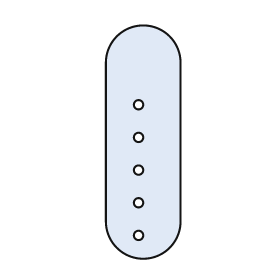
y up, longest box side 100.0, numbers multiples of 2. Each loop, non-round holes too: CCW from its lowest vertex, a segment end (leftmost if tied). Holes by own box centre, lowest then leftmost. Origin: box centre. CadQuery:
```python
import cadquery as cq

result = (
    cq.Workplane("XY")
    .moveTo(-16.0, -34.0)
    .threePointArc((0.0, -50.0), (16.0, -34.0))
    .lineTo(16.0, 34.0)
    .threePointArc((0.0, 50.0), (-16.0, 34.0))
    .close()
    .moveTo(-2.0, -40.0)
    .circle(2.0)
    .moveTo(-2.0, -26.0)
    .circle(2.0)
    .moveTo(-2.0, -12.0)
    .circle(2.0)
    .moveTo(-2.0, 2.0)
    .circle(2.0)
    .moveTo(-2.0, 16.0)
    .circle(2.0)
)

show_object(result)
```